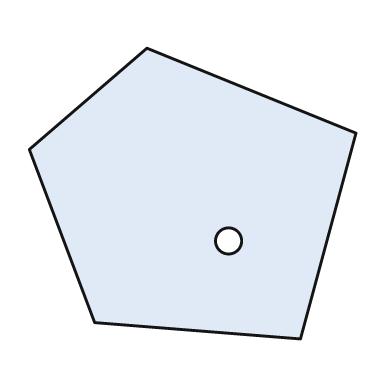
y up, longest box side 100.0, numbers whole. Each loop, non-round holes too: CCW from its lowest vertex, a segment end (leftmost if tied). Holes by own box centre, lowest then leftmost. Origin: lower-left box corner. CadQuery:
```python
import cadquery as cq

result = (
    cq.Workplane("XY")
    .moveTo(83.0, 0.0)
    .lineTo(100.0, 63.0)
    .lineTo(36.0, 89.0)
    .lineTo(0.0, 58.0)
    .lineTo(20.0, 5.0)
    .close()
    .moveTo(61.0, 30.0)
    .circle(4.0)
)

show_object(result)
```